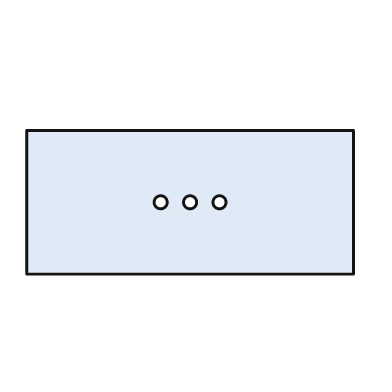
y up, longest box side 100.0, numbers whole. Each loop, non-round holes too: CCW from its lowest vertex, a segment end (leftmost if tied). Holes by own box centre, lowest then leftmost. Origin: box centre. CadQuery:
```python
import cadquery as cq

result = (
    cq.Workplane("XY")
    .moveTo(-50.0, -22.0)
    .lineTo(50.0, -22.0)
    .lineTo(50.0, 22.0)
    .lineTo(-50.0, 22.0)
    .close()
    .moveTo(-9.0, 0.0)
    .circle(2.0)
    .moveTo(0.0, 0.0)
    .circle(2.0)
    .moveTo(9.0, 0.0)
    .circle(2.0)
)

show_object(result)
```